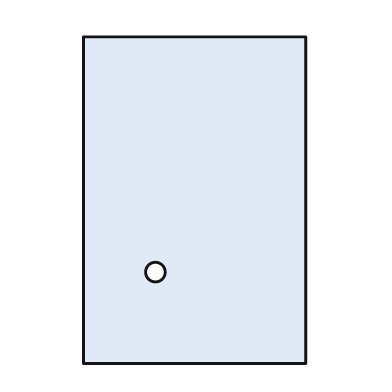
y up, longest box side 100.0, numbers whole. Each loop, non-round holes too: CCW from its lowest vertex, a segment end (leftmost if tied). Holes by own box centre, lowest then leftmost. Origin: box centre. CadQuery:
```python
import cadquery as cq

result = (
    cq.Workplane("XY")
    .moveTo(-34.0, -50.0)
    .lineTo(34.0, -50.0)
    .lineTo(34.0, 50.0)
    .lineTo(-34.0, 50.0)
    .close()
    .moveTo(-12.0, -22.0)
    .circle(3.0)
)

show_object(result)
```